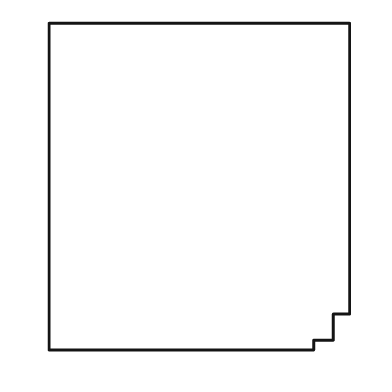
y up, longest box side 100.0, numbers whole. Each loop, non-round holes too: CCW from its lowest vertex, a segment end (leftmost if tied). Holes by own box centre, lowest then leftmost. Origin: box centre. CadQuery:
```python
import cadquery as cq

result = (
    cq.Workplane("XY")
    .moveTo(-46.0, -50.0)
    .lineTo(35.0, -50.0)
    .lineTo(35.0, -47.0)
    .lineTo(41.0, -47.0)
    .lineTo(41.0, -39.0)
    .lineTo(46.0, -39.0)
    .lineTo(46.0, 50.0)
    .lineTo(-46.0, 50.0)
    .close()
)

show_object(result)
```